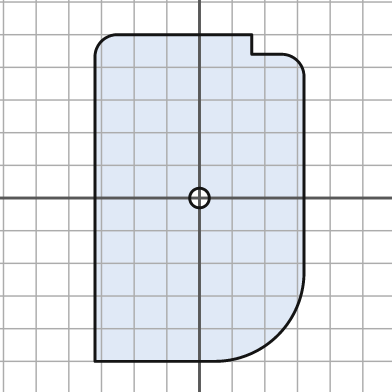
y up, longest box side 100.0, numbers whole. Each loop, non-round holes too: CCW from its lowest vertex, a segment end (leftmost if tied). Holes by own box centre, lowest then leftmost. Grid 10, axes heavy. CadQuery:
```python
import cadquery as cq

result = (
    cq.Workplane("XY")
    .moveTo(-32.0, -50.0)
    .lineTo(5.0, -50.0)
    .threePointArc((24.0, -42.0), (32.0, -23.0))
    .lineTo(32.0, 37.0)
    .threePointArc((30.0, 42.0), (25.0, 44.0))
    .lineTo(16.0, 44.0)
    .lineTo(16.0, 50.0)
    .lineTo(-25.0, 50.0)
    .threePointArc((-30.0, 48.0), (-32.0, 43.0))
    .close()
    .moveTo(0.0, 0.0)
    .circle(3.0)
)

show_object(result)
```